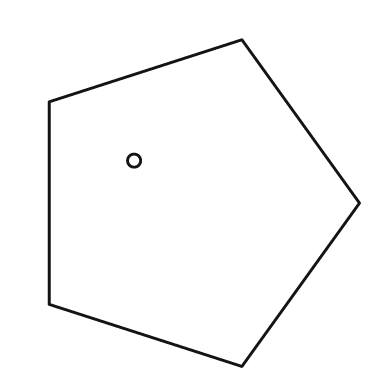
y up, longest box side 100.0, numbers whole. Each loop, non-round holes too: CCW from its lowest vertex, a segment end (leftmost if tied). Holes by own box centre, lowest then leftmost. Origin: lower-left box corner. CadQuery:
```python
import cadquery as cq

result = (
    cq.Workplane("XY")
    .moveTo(59.0, 0.0)
    .lineTo(95.0, 50.0)
    .lineTo(59.0, 100.0)
    .lineTo(0.0, 81.0)
    .lineTo(0.0, 19.0)
    .close()
    .moveTo(26.0, 63.0)
    .circle(2.0)
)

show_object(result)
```